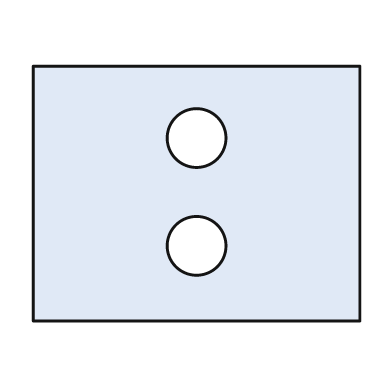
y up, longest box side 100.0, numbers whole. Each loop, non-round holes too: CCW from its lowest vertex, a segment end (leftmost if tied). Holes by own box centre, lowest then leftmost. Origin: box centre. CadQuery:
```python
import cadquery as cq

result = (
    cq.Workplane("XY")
    .moveTo(-50.0, -39.0)
    .lineTo(50.0, -39.0)
    .lineTo(50.0, 39.0)
    .lineTo(-50.0, 39.0)
    .close()
    .moveTo(0.0, -16.0)
    .circle(9.0)
    .moveTo(0.0, 17.0)
    .circle(9.0)
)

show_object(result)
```